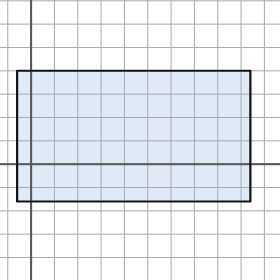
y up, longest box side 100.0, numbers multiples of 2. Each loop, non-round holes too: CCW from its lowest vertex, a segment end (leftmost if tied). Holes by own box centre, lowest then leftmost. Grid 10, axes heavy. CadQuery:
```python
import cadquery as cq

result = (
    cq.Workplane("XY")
    .moveTo(-6.0, -16.0)
    .lineTo(94.0, -16.0)
    .lineTo(94.0, 40.0)
    .lineTo(-6.0, 40.0)
    .close()
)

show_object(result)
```